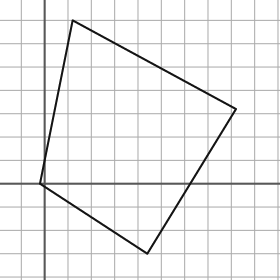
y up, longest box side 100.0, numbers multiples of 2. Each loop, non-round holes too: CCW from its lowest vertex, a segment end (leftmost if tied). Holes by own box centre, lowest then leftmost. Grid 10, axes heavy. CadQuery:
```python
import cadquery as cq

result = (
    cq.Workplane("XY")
    .moveTo(44.0, -30.0)
    .lineTo(82.0, 32.0)
    .lineTo(12.0, 70.0)
    .lineTo(-2.0, 0.0)
    .close()
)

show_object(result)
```